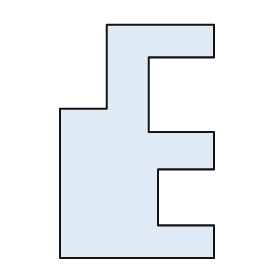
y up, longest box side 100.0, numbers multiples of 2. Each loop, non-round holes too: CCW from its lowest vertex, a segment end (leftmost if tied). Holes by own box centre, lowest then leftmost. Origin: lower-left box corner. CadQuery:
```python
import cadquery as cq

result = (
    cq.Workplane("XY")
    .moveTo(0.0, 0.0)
    .lineTo(66.0, 0.0)
    .lineTo(66.0, 14.0)
    .lineTo(42.0, 14.0)
    .lineTo(42.0, 38.0)
    .lineTo(66.0, 38.0)
    .lineTo(66.0, 54.0)
    .lineTo(38.0, 54.0)
    .lineTo(38.0, 86.0)
    .lineTo(66.0, 86.0)
    .lineTo(66.0, 100.0)
    .lineTo(20.0, 100.0)
    .lineTo(20.0, 64.0)
    .lineTo(0.0, 64.0)
    .close()
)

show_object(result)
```